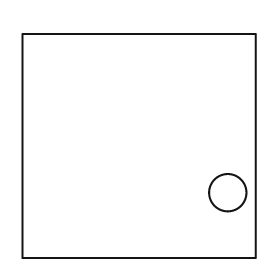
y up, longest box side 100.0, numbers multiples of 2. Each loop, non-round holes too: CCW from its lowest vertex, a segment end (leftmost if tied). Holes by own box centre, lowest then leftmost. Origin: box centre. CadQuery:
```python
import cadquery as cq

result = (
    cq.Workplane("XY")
    .moveTo(-50.0, -48.0)
    .lineTo(50.0, -48.0)
    .lineTo(50.0, 48.0)
    .lineTo(-50.0, 48.0)
    .close()
    .moveTo(38.0, -20.0)
    .circle(8.0)
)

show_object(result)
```